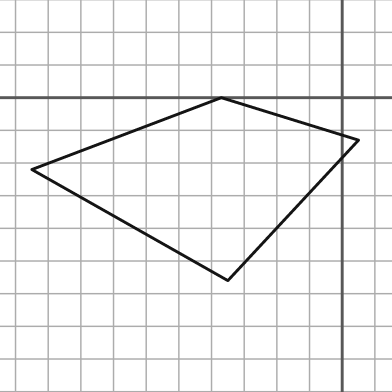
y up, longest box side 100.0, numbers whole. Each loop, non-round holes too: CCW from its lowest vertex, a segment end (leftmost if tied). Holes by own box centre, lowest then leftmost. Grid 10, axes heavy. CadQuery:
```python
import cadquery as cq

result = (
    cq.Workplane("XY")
    .moveTo(-35.0, -56.0)
    .lineTo(5.0, -13.0)
    .lineTo(-37.0, 0.0)
    .lineTo(-95.0, -22.0)
    .close()
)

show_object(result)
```